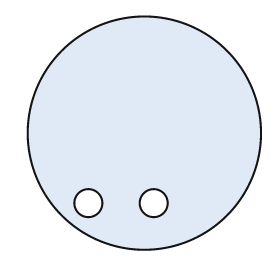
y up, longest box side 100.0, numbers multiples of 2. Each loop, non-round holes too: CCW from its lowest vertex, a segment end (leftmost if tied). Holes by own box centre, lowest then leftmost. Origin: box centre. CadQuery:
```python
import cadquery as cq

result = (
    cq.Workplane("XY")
    .moveTo(0.0, 0.0)
    .circle(50.0)
    .moveTo(-24.0, -30.0)
    .circle(6.0)
    .moveTo(4.0, -30.0)
    .circle(6.0)
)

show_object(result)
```